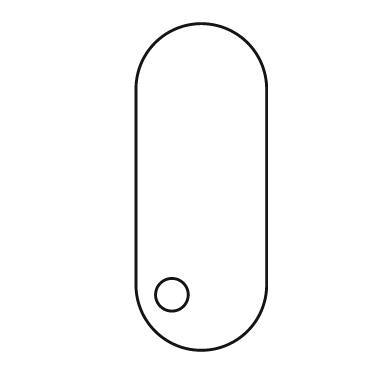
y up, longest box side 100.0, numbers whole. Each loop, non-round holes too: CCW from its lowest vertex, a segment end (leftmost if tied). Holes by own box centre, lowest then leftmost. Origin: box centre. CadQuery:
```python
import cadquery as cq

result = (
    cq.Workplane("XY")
    .moveTo(-20.0, -30.0)
    .threePointArc((0.0, -50.0), (20.0, -30.0))
    .lineTo(20.0, 30.0)
    .threePointArc((0.0, 50.0), (-20.0, 30.0))
    .close()
    .moveTo(-9.0, -33.0)
    .circle(5.0)
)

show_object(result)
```